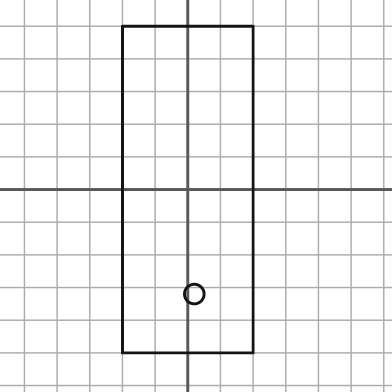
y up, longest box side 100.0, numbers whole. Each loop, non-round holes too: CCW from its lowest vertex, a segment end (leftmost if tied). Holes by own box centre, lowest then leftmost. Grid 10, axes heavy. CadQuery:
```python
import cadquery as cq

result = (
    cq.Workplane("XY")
    .moveTo(-20.0, -50.0)
    .lineTo(20.0, -50.0)
    .lineTo(20.0, 50.0)
    .lineTo(-20.0, 50.0)
    .close()
    .moveTo(2.0, -32.0)
    .circle(3.0)
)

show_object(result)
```